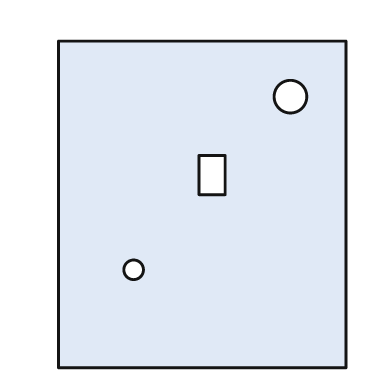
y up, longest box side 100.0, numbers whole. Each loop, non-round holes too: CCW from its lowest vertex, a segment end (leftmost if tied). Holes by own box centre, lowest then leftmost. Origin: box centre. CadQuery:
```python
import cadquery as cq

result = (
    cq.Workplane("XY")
    .moveTo(-44.0, -50.0)
    .lineTo(44.0, -50.0)
    .lineTo(44.0, 50.0)
    .lineTo(-44.0, 50.0)
    .close()
    .moveTo(-21.0, -20.0)
    .circle(3.0)
    .moveTo(-1.0, 3.0)
    .lineTo(7.0, 3.0)
    .lineTo(7.0, 15.0)
    .lineTo(-1.0, 15.0)
    .close()
    .moveTo(27.0, 33.0)
    .circle(5.0)
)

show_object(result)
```